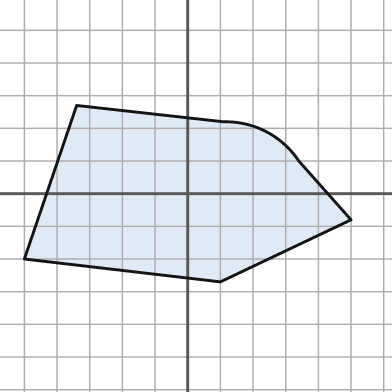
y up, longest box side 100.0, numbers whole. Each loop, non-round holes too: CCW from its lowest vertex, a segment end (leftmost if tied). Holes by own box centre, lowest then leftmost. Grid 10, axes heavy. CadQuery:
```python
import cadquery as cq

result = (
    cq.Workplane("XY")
    .moveTo(10.0, -27.0)
    .lineTo(50.0, -8.0)
    .lineTo(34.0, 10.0)
    .threePointArc((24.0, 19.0), (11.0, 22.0))
    .lineTo(-34.0, 27.0)
    .lineTo(-50.0, -20.0)
    .close()
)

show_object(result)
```